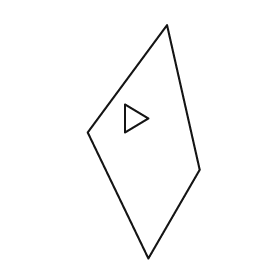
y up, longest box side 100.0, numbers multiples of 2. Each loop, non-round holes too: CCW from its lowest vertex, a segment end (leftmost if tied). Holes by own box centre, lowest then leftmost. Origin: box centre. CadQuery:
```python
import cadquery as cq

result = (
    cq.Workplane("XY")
    .moveTo(2.0, -50.0)
    .lineTo(24.0, -12.0)
    .lineTo(10.0, 50.0)
    .lineTo(-24.0, 4.0)
    .close()
    .moveTo(-8.0, 4.0)
    .lineTo(2.0, 10.0)
    .lineTo(-8.0, 16.0)
    .close()
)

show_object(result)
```